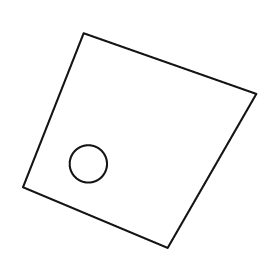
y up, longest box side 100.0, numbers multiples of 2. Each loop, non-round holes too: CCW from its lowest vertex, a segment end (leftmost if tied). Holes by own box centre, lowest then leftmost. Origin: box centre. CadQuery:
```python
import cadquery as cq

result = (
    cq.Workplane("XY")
    .moveTo(12.0, -46.0)
    .lineTo(50.0, 20.0)
    .lineTo(-24.0, 46.0)
    .lineTo(-50.0, -20.0)
    .close()
    .moveTo(-22.0, -10.0)
    .circle(8.0)
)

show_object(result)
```